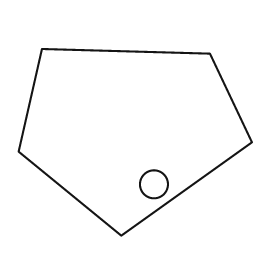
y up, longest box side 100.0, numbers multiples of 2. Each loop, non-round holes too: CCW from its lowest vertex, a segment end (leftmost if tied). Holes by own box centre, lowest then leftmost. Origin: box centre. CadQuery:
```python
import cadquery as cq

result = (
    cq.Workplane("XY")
    .moveTo(-6.0, -40.0)
    .lineTo(50.0, 0.0)
    .lineTo(32.0, 38.0)
    .lineTo(-40.0, 40.0)
    .lineTo(-50.0, -4.0)
    .close()
    .moveTo(8.0, -18.0)
    .circle(6.0)
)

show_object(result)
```